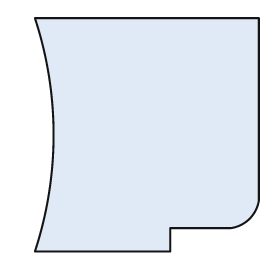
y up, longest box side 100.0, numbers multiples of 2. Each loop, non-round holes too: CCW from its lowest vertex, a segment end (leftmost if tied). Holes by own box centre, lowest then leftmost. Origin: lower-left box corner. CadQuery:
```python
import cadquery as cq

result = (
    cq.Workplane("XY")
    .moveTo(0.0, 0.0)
    .lineTo(58.0, 0.0)
    .lineTo(58.0, 10.0)
    .lineTo(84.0, 10.0)
    .threePointArc((92.0, 14.0), (96.0, 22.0))
    .lineTo(96.0, 100.0)
    .lineTo(0.0, 100.0)
    .threePointArc((8.0, 50.0), (0.0, 0.0))
    .close()
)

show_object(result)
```